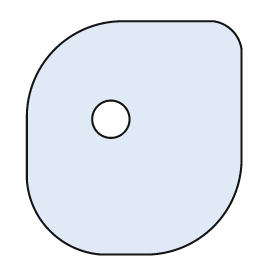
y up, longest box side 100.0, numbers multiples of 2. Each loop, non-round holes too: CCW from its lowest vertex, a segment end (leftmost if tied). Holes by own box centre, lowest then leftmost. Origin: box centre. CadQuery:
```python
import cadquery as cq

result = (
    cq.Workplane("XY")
    .moveTo(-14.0, -50.0)
    .lineTo(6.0, -50.0)
    .threePointArc((34.0, -38.0), (46.0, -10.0))
    .lineTo(46.0, 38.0)
    .threePointArc((42.0, 46.0), (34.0, 50.0))
    .lineTo(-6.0, 50.0)
    .threePointArc((-34.0, 38.0), (-46.0, 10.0))
    .lineTo(-46.0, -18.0)
    .threePointArc((-36.0, -40.0), (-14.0, -50.0))
    .close()
    .moveTo(-10.0, 8.0)
    .circle(8.0)
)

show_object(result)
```